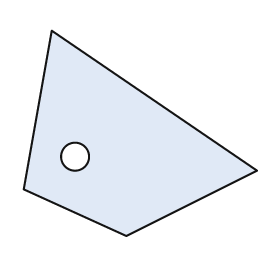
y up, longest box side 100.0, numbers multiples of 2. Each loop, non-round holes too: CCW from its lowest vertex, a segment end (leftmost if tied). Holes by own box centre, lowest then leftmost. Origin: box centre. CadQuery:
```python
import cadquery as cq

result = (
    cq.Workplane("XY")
    .moveTo(-6.0, -44.0)
    .lineTo(50.0, -16.0)
    .lineTo(-38.0, 44.0)
    .lineTo(-50.0, -24.0)
    .close()
    .moveTo(-28.0, -10.0)
    .circle(6.0)
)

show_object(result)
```